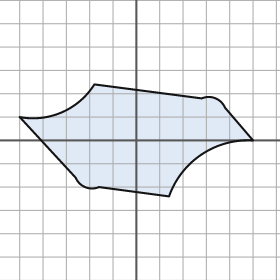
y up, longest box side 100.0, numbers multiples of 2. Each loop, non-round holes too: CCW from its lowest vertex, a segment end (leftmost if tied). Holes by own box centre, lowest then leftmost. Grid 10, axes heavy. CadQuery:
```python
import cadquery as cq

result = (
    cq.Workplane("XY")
    .moveTo(14.0, -24.0)
    .threePointArc((28.0, -6.0), (50.0, 0.0))
    .lineTo(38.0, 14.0)
    .threePointArc((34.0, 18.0), (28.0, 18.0))
    .lineTo(-18.0, 24.0)
    .threePointArc((-32.0, 12.0), (-50.0, 10.0))
    .lineTo(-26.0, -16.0)
    .threePointArc((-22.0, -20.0), (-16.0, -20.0))
    .close()
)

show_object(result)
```